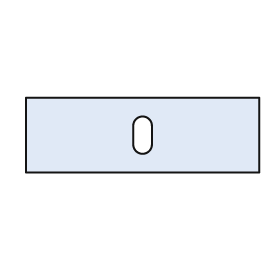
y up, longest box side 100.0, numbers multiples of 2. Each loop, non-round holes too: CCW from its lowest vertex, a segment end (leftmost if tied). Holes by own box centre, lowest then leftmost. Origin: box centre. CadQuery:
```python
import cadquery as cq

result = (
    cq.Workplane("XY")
    .moveTo(-50.0, -16.0)
    .lineTo(50.0, -16.0)
    .lineTo(50.0, 16.0)
    .lineTo(-50.0, 16.0)
    .close()
    .moveTo(-4.0, -4.0)
    .threePointArc((0.0, -8.0), (4.0, -4.0))
    .lineTo(4.0, 4.0)
    .threePointArc((0.0, 8.0), (-4.0, 4.0))
    .close()
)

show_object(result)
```